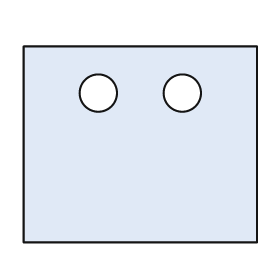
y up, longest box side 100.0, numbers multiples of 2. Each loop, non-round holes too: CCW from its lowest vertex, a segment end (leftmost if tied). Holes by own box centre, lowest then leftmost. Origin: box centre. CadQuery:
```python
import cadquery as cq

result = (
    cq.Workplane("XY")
    .moveTo(-50.0, -42.0)
    .lineTo(50.0, -42.0)
    .lineTo(50.0, 42.0)
    .lineTo(-50.0, 42.0)
    .close()
    .moveTo(-18.0, 22.0)
    .circle(8.0)
    .moveTo(18.0, 22.0)
    .circle(8.0)
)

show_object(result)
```